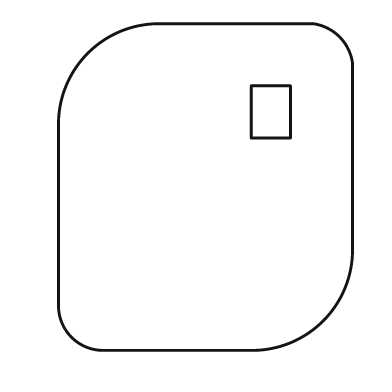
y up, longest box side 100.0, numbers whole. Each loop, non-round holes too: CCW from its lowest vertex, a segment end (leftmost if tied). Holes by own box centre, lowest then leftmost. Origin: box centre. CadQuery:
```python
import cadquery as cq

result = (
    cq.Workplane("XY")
    .moveTo(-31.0, -50.0)
    .lineTo(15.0, -50.0)
    .threePointArc((36.0, -41.0), (45.0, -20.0))
    .lineTo(45.0, 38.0)
    .threePointArc((41.0, 46.0), (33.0, 50.0))
    .lineTo(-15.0, 50.0)
    .threePointArc((-36.0, 41.0), (-45.0, 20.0))
    .lineTo(-45.0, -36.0)
    .threePointArc((-41.0, -46.0), (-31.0, -50.0))
    .close()
    .moveTo(14.0, 15.0)
    .lineTo(26.0, 15.0)
    .lineTo(26.0, 31.0)
    .lineTo(14.0, 31.0)
    .close()
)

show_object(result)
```